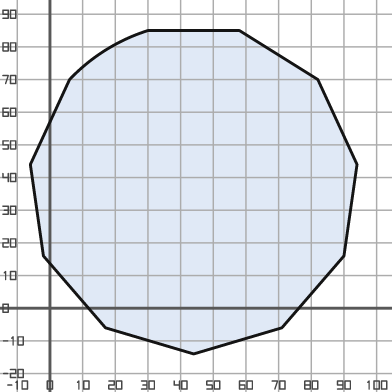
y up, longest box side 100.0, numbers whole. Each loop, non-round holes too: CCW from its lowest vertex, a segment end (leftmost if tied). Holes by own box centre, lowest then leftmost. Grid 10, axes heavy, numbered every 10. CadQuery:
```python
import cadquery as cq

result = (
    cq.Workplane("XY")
    .moveTo(44.0, -14.0)
    .lineTo(71.0, -6.0)
    .lineTo(90.0, 16.0)
    .lineTo(94.0, 44.0)
    .lineTo(82.0, 70.0)
    .lineTo(58.0, 85.0)
    .lineTo(30.0, 85.0)
    .threePointArc((17.0, 79.0), (6.0, 70.0))
    .lineTo(-6.0, 44.0)
    .lineTo(-2.0, 16.0)
    .lineTo(17.0, -6.0)
    .close()
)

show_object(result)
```